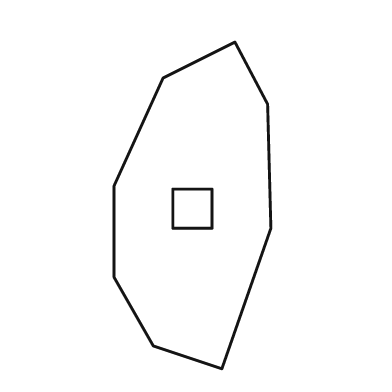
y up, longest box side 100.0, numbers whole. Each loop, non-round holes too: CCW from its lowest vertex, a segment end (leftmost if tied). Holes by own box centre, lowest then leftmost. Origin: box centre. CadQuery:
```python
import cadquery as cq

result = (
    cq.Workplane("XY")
    .moveTo(9.0, -50.0)
    .lineTo(24.0, -7.0)
    .lineTo(23.0, 31.0)
    .lineTo(13.0, 50.0)
    .lineTo(-9.0, 39.0)
    .lineTo(-24.0, 6.0)
    .lineTo(-24.0, -22.0)
    .lineTo(-12.0, -43.0)
    .close()
    .moveTo(-6.0, -7.0)
    .lineTo(6.0, -7.0)
    .lineTo(6.0, 5.0)
    .lineTo(-6.0, 5.0)
    .close()
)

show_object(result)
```